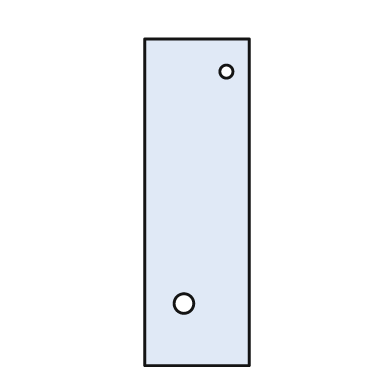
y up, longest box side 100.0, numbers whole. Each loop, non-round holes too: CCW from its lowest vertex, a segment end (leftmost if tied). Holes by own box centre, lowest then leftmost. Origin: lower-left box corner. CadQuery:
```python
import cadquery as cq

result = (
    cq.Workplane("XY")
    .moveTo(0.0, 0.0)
    .lineTo(32.0, 0.0)
    .lineTo(32.0, 100.0)
    .lineTo(0.0, 100.0)
    .close()
    .moveTo(12.0, 19.0)
    .circle(3.0)
    .moveTo(25.0, 90.0)
    .circle(2.0)
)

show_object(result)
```